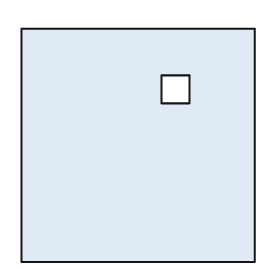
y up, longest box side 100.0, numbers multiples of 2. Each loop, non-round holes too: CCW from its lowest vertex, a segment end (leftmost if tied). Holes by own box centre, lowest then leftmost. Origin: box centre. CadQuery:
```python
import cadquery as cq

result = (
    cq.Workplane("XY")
    .moveTo(-50.0, -50.0)
    .lineTo(50.0, -50.0)
    .lineTo(50.0, 50.0)
    .lineTo(-50.0, 50.0)
    .close()
    .moveTo(10.0, 18.0)
    .lineTo(22.0, 18.0)
    .lineTo(22.0, 30.0)
    .lineTo(10.0, 30.0)
    .close()
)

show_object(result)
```